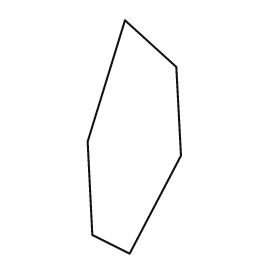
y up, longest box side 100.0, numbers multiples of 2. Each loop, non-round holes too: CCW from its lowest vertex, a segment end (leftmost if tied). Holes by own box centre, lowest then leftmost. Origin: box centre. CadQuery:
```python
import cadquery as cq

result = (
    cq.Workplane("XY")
    .moveTo(-2.0, -50.0)
    .lineTo(20.0, -8.0)
    .lineTo(18.0, 30.0)
    .lineTo(-4.0, 50.0)
    .lineTo(-20.0, -2.0)
    .lineTo(-18.0, -42.0)
    .close()
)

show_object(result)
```